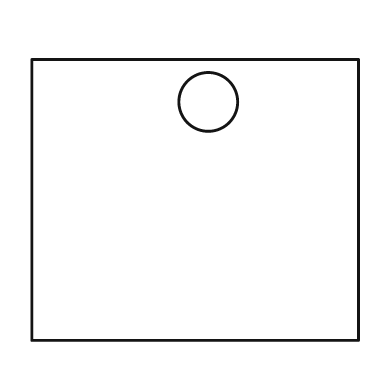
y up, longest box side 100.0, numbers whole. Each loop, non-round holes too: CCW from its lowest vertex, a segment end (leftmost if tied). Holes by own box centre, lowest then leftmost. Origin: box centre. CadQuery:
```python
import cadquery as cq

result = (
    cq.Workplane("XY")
    .moveTo(-50.0, -43.0)
    .lineTo(50.0, -43.0)
    .lineTo(50.0, 43.0)
    .lineTo(-50.0, 43.0)
    .close()
    .moveTo(4.0, 30.0)
    .circle(9.0)
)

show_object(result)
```